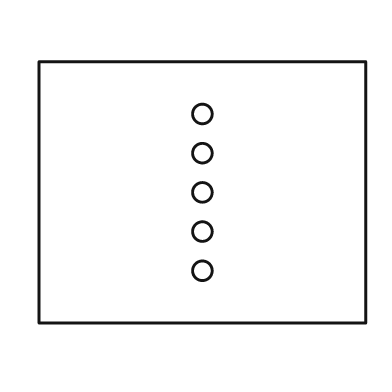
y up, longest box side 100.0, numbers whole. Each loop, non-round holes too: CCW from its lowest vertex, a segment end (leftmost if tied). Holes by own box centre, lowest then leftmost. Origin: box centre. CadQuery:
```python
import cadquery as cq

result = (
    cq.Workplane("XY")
    .moveTo(-50.0, -40.0)
    .lineTo(50.0, -40.0)
    .lineTo(50.0, 40.0)
    .lineTo(-50.0, 40.0)
    .close()
    .moveTo(0.0, -24.0)
    .circle(3.0)
    .moveTo(0.0, -12.0)
    .circle(3.0)
    .moveTo(0.0, 0.0)
    .circle(3.0)
    .moveTo(0.0, 12.0)
    .circle(3.0)
    .moveTo(0.0, 24.0)
    .circle(3.0)
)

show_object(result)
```